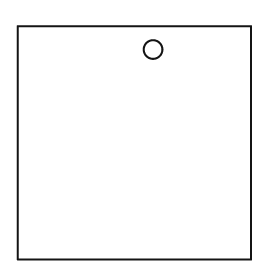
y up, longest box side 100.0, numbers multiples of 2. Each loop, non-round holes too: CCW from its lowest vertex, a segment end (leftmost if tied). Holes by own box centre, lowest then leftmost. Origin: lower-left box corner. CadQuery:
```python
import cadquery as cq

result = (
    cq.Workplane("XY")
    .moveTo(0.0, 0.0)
    .lineTo(100.0, 0.0)
    .lineTo(100.0, 100.0)
    .lineTo(0.0, 100.0)
    .close()
    .moveTo(58.0, 90.0)
    .circle(4.0)
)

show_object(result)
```